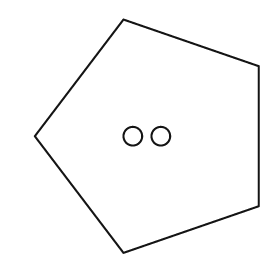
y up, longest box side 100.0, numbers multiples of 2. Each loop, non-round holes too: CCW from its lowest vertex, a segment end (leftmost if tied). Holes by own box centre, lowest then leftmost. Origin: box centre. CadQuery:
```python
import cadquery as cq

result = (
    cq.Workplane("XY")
    .moveTo(-10.0, -50.0)
    .lineTo(48.0, -30.0)
    .lineTo(48.0, 30.0)
    .lineTo(-10.0, 50.0)
    .lineTo(-48.0, 0.0)
    .close()
    .moveTo(-6.0, 0.0)
    .circle(4.0)
    .moveTo(6.0, 0.0)
    .circle(4.0)
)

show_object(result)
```